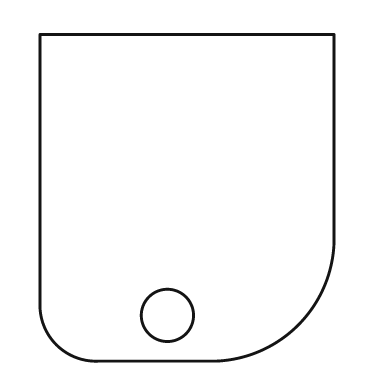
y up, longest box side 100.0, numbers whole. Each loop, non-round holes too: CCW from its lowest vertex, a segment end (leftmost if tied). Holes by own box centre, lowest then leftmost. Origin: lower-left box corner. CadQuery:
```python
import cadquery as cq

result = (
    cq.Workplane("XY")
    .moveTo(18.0, 0.0)
    .lineTo(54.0, 0.0)
    .threePointArc((79.0, 11.0), (90.0, 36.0))
    .lineTo(90.0, 100.0)
    .lineTo(0.0, 100.0)
    .lineTo(0.0, 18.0)
    .threePointArc((5.0, 5.0), (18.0, 0.0))
    .close()
    .moveTo(39.0, 14.0)
    .circle(8.0)
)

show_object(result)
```